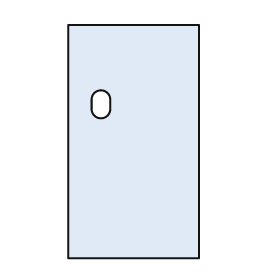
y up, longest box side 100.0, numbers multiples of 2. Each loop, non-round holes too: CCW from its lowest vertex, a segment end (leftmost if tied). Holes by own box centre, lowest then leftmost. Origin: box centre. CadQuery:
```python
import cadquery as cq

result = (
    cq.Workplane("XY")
    .moveTo(-28.0, -50.0)
    .lineTo(28.0, -50.0)
    .lineTo(28.0, 50.0)
    .lineTo(-28.0, 50.0)
    .close()
    .moveTo(-18.0, 14.0)
    .threePointArc((-14.0, 10.0), (-10.0, 14.0))
    .lineTo(-10.0, 18.0)
    .threePointArc((-14.0, 22.0), (-18.0, 18.0))
    .close()
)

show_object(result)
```